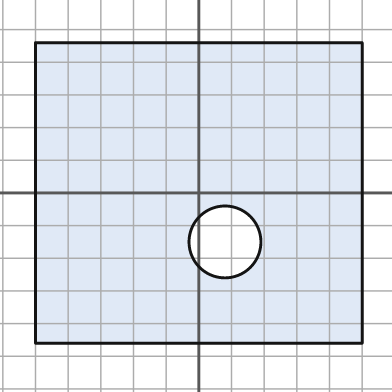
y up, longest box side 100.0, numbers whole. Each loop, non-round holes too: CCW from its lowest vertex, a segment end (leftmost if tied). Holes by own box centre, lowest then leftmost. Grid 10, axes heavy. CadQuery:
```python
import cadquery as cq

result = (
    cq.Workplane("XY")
    .moveTo(-50.0, -46.0)
    .lineTo(50.0, -46.0)
    .lineTo(50.0, 46.0)
    .lineTo(-50.0, 46.0)
    .close()
    .moveTo(8.0, -15.0)
    .circle(11.0)
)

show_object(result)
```